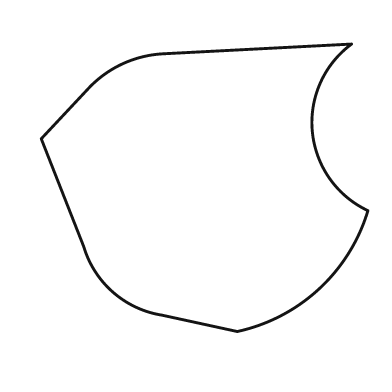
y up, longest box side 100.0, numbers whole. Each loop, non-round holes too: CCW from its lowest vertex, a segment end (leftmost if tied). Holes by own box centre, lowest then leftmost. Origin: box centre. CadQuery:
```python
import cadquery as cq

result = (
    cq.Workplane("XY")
    .moveTo(10.0, -44.0)
    .threePointArc((35.0, -31.0), (50.0, -7.0))
    .threePointArc((33.0, 17.0), (45.0, 44.0))
    .lineTo(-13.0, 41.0)
    .threePointArc((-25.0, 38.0), (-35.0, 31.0))
    .lineTo(-50.0, 15.0)
    .lineTo(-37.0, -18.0)
    .threePointArc((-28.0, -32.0), (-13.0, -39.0))
    .close()
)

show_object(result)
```